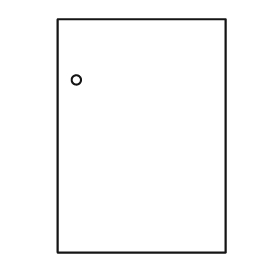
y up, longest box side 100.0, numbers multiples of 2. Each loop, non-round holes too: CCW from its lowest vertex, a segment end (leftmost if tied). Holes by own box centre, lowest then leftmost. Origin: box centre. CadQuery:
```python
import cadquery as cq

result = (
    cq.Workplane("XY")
    .moveTo(-36.0, -50.0)
    .lineTo(36.0, -50.0)
    .lineTo(36.0, 50.0)
    .lineTo(-36.0, 50.0)
    .close()
    .moveTo(-28.0, 24.0)
    .circle(2.0)
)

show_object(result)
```